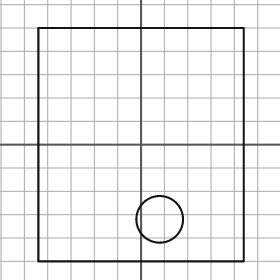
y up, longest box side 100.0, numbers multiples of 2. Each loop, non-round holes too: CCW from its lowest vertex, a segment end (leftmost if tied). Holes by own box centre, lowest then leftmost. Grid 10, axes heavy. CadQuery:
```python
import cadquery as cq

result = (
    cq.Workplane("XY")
    .moveTo(-44.0, -50.0)
    .lineTo(44.0, -50.0)
    .lineTo(44.0, 50.0)
    .lineTo(-44.0, 50.0)
    .close()
    .moveTo(8.0, -32.0)
    .circle(10.0)
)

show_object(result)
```